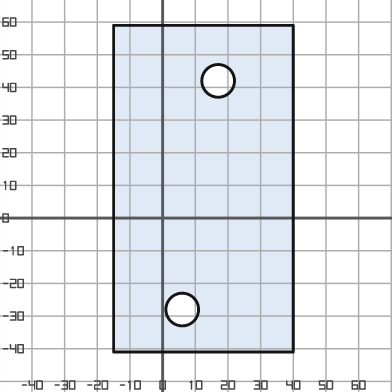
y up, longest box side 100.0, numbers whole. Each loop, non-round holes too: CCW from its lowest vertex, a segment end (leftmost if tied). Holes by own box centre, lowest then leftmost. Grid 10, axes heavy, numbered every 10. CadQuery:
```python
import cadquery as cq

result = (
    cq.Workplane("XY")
    .moveTo(-15.0, -41.0)
    .lineTo(40.0, -41.0)
    .lineTo(40.0, 59.0)
    .lineTo(-15.0, 59.0)
    .close()
    .moveTo(6.0, -28.0)
    .circle(5.0)
    .moveTo(17.0, 42.0)
    .circle(5.0)
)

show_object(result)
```